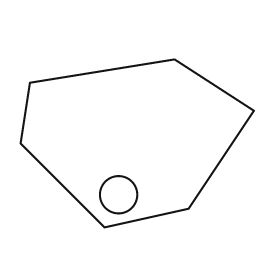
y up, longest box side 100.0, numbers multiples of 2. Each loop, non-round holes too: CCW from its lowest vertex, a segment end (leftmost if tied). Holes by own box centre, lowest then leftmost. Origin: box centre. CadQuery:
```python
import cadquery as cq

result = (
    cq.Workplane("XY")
    .moveTo(-14.0, -36.0)
    .lineTo(22.0, -28.0)
    .lineTo(50.0, 14.0)
    .lineTo(16.0, 36.0)
    .lineTo(-46.0, 26.0)
    .lineTo(-50.0, 0.0)
    .close()
    .moveTo(-8.0, -22.0)
    .circle(8.0)
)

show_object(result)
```